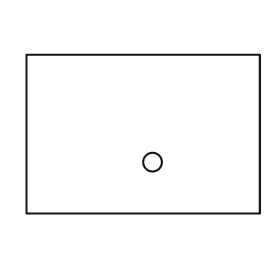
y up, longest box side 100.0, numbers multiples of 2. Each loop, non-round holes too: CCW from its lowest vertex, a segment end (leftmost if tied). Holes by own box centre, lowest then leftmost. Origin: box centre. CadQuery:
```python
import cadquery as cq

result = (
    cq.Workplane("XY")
    .moveTo(-50.0, -34.0)
    .lineTo(50.0, -34.0)
    .lineTo(50.0, 34.0)
    .lineTo(-50.0, 34.0)
    .close()
    .moveTo(4.0, -12.0)
    .circle(4.0)
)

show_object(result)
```